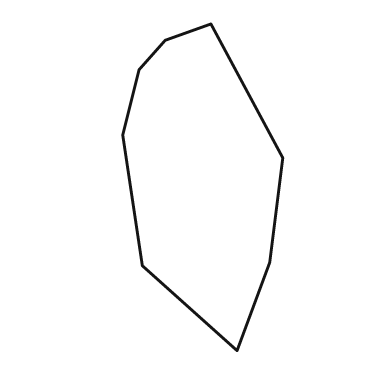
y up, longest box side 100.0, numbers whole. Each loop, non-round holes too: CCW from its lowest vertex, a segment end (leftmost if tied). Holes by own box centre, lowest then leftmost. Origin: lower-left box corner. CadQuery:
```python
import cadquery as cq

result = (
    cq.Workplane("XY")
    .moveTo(35.0, 0.0)
    .lineTo(45.0, 27.0)
    .lineTo(49.0, 59.0)
    .lineTo(27.0, 100.0)
    .lineTo(13.0, 95.0)
    .lineTo(5.0, 86.0)
    .lineTo(0.0, 66.0)
    .lineTo(6.0, 26.0)
    .close()
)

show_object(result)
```